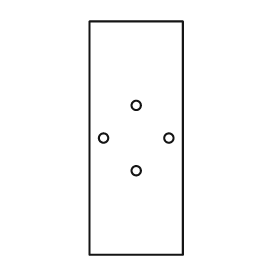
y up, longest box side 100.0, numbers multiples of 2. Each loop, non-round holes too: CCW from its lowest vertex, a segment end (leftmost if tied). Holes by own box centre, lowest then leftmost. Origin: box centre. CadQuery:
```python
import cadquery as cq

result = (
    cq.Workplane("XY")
    .moveTo(-20.0, -50.0)
    .lineTo(20.0, -50.0)
    .lineTo(20.0, 50.0)
    .lineTo(-20.0, 50.0)
    .close()
    .moveTo(0.0, -14.0)
    .circle(2.0)
    .moveTo(-14.0, 0.0)
    .circle(2.0)
    .moveTo(14.0, 0.0)
    .circle(2.0)
    .moveTo(0.0, 14.0)
    .circle(2.0)
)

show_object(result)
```